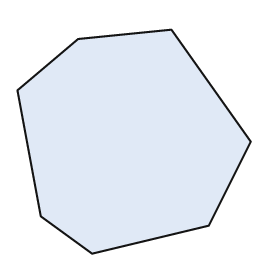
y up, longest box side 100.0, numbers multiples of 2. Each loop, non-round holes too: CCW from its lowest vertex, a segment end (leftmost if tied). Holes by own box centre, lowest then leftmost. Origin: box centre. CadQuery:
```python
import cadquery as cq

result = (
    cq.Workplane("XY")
    .moveTo(-18.0, -48.0)
    .lineTo(32.0, -36.0)
    .lineTo(50.0, 0.0)
    .lineTo(16.0, 48.0)
    .lineTo(-24.0, 44.0)
    .lineTo(-50.0, 22.0)
    .lineTo(-40.0, -32.0)
    .close()
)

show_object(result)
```